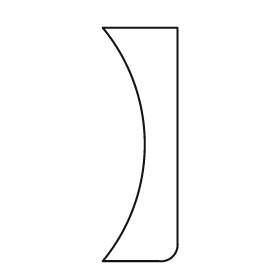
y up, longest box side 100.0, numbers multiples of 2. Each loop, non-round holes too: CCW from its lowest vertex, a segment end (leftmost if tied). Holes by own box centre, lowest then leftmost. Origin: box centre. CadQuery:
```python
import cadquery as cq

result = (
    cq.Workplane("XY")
    .moveTo(-16.0, -50.0)
    .lineTo(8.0, -50.0)
    .threePointArc((14.0, -48.0), (16.0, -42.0))
    .lineTo(16.0, 50.0)
    .lineTo(-16.0, 50.0)
    .threePointArc((2.0, 0.0), (-16.0, -50.0))
    .close()
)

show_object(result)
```